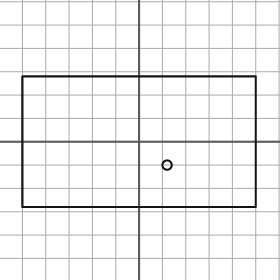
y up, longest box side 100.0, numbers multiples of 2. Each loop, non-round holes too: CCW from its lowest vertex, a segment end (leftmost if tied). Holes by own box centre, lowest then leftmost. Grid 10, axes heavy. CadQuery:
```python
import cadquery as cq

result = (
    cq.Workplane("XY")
    .moveTo(-50.0, -28.0)
    .lineTo(50.0, -28.0)
    .lineTo(50.0, 28.0)
    .lineTo(-50.0, 28.0)
    .close()
    .moveTo(12.0, -10.0)
    .circle(2.0)
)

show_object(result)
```